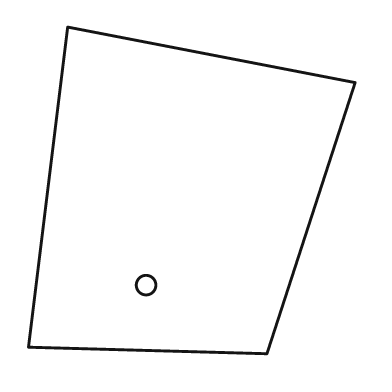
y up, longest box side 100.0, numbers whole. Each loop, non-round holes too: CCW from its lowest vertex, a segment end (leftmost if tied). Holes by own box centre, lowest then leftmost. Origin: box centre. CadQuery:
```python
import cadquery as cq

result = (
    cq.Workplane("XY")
    .moveTo(23.0, -50.0)
    .lineTo(50.0, 33.0)
    .lineTo(-38.0, 50.0)
    .lineTo(-50.0, -48.0)
    .close()
    .moveTo(-14.0, -29.0)
    .circle(3.0)
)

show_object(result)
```